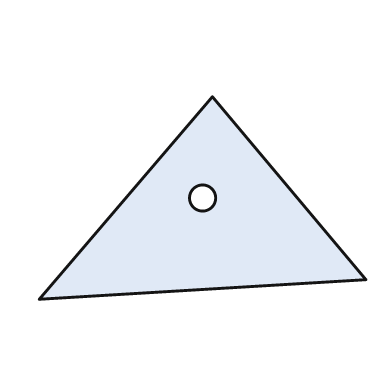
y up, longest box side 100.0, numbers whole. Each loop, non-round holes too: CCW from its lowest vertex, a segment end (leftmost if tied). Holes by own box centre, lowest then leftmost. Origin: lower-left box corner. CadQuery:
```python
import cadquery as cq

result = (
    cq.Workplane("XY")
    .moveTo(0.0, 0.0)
    .lineTo(100.0, 6.0)
    .lineTo(53.0, 62.0)
    .close()
    .moveTo(50.0, 31.0)
    .circle(4.0)
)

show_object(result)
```